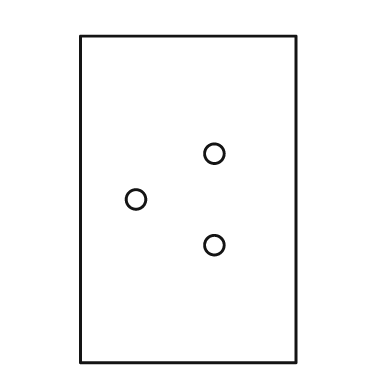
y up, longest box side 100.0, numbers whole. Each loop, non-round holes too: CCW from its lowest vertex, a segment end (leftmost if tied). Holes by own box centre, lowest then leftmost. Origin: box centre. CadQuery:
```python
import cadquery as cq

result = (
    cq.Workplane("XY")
    .moveTo(-33.0, -50.0)
    .lineTo(33.0, -50.0)
    .lineTo(33.0, 50.0)
    .lineTo(-33.0, 50.0)
    .close()
    .moveTo(8.0, -14.0)
    .circle(3.0)
    .moveTo(-16.0, 0.0)
    .circle(3.0)
    .moveTo(8.0, 14.0)
    .circle(3.0)
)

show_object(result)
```